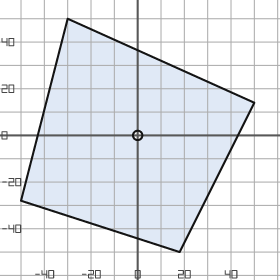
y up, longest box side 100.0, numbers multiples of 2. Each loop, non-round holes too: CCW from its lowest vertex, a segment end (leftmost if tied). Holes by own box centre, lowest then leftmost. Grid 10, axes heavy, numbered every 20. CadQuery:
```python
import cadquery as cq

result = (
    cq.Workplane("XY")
    .moveTo(18.0, -50.0)
    .lineTo(50.0, 14.0)
    .lineTo(-30.0, 50.0)
    .lineTo(-50.0, -28.0)
    .close()
    .moveTo(0.0, 0.0)
    .circle(2.0)
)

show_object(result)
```